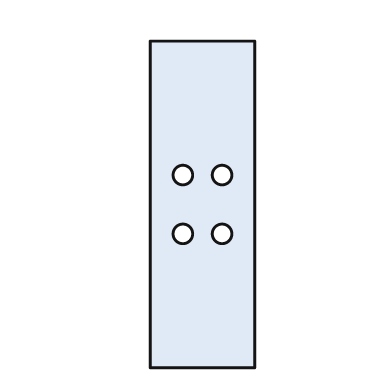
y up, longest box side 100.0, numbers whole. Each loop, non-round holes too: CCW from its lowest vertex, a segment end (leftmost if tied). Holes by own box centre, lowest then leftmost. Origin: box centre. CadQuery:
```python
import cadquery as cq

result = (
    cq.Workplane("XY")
    .moveTo(-16.0, -50.0)
    .lineTo(16.0, -50.0)
    .lineTo(16.0, 50.0)
    .lineTo(-16.0, 50.0)
    .close()
    .moveTo(-6.0, -9.0)
    .circle(3.0)
    .moveTo(6.0, -9.0)
    .circle(3.0)
    .moveTo(-6.0, 9.0)
    .circle(3.0)
    .moveTo(6.0, 9.0)
    .circle(3.0)
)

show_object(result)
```